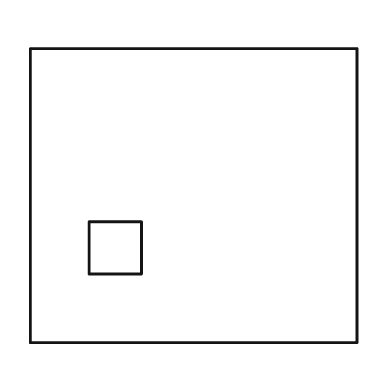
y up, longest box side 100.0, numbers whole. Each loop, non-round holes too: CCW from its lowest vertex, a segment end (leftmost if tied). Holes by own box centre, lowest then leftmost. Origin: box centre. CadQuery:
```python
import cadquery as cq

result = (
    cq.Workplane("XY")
    .moveTo(-50.0, -45.0)
    .lineTo(50.0, -45.0)
    .lineTo(50.0, 45.0)
    .lineTo(-50.0, 45.0)
    .close()
    .moveTo(-32.0, -24.0)
    .lineTo(-16.0, -24.0)
    .lineTo(-16.0, -8.0)
    .lineTo(-32.0, -8.0)
    .close()
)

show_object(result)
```